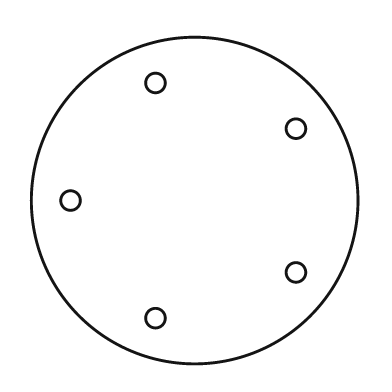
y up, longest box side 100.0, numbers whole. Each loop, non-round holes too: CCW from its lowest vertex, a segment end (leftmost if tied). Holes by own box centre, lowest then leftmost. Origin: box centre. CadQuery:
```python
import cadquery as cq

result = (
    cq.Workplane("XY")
    .moveTo(0.0, 0.0)
    .circle(50.0)
    .moveTo(-12.0, -36.0)
    .circle(3.0)
    .moveTo(31.0, -22.0)
    .circle(3.0)
    .moveTo(-38.0, 0.0)
    .circle(3.0)
    .moveTo(31.0, 22.0)
    .circle(3.0)
    .moveTo(-12.0, 36.0)
    .circle(3.0)
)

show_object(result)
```